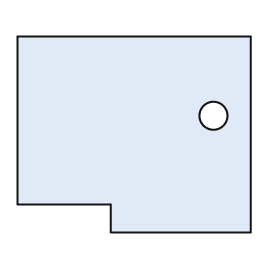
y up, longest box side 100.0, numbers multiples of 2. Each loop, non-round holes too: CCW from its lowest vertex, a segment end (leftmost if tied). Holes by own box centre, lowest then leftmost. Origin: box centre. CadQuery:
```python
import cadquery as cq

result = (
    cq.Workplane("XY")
    .moveTo(-10.0, -42.0)
    .lineTo(50.0, -42.0)
    .lineTo(50.0, 42.0)
    .lineTo(-50.0, 42.0)
    .lineTo(-50.0, -30.0)
    .lineTo(-10.0, -30.0)
    .close()
    .moveTo(34.0, 8.0)
    .circle(6.0)
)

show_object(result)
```